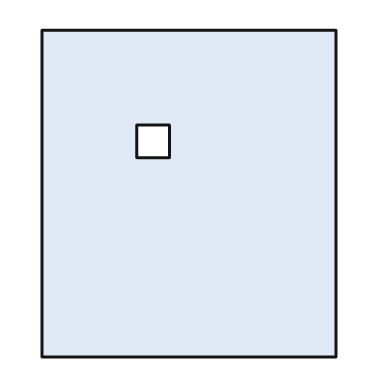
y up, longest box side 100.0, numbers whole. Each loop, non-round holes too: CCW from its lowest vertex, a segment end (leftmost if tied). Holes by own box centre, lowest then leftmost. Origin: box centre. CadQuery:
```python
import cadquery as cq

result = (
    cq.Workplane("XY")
    .moveTo(-45.0, -50.0)
    .lineTo(45.0, -50.0)
    .lineTo(45.0, 50.0)
    .lineTo(-45.0, 50.0)
    .close()
    .moveTo(-16.0, 11.0)
    .lineTo(-6.0, 11.0)
    .lineTo(-6.0, 21.0)
    .lineTo(-16.0, 21.0)
    .close()
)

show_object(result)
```